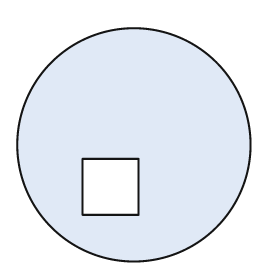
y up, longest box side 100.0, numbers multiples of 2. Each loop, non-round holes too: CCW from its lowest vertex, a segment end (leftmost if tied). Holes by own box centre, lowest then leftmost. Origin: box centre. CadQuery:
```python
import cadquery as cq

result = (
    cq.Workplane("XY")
    .moveTo(0.0, 0.0)
    .circle(50.0)
    .moveTo(-22.0, -30.0)
    .lineTo(2.0, -30.0)
    .lineTo(2.0, -6.0)
    .lineTo(-22.0, -6.0)
    .close()
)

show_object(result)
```